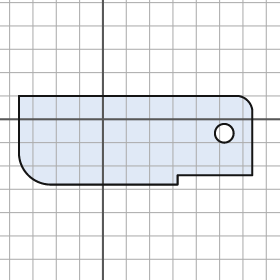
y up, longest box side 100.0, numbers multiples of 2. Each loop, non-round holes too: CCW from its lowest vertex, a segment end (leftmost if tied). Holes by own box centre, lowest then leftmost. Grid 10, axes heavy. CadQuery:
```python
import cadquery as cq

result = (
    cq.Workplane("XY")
    .moveTo(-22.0, -28.0)
    .lineTo(32.0, -28.0)
    .lineTo(32.0, -24.0)
    .lineTo(64.0, -24.0)
    .lineTo(64.0, 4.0)
    .threePointArc((62.0, 8.0), (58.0, 10.0))
    .lineTo(-36.0, 10.0)
    .lineTo(-36.0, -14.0)
    .threePointArc((-32.0, -24.0), (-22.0, -28.0))
    .close()
    .moveTo(52.0, -6.0)
    .circle(4.0)
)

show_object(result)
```